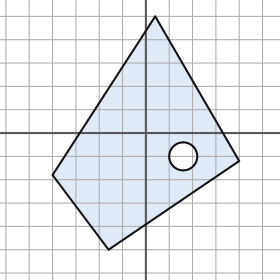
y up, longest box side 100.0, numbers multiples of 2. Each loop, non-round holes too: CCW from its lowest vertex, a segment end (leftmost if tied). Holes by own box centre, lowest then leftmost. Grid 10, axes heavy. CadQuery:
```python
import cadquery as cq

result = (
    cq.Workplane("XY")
    .moveTo(-16.0, -50.0)
    .lineTo(40.0, -12.0)
    .lineTo(4.0, 50.0)
    .lineTo(-40.0, -18.0)
    .close()
    .moveTo(16.0, -10.0)
    .circle(6.0)
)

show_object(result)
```